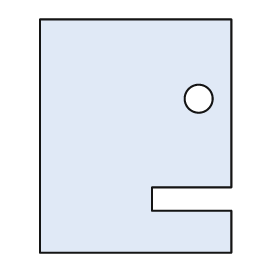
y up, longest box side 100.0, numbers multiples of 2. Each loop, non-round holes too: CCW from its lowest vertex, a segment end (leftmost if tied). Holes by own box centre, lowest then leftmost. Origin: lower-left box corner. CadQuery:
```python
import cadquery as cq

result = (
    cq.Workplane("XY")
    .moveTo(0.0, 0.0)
    .lineTo(82.0, 0.0)
    .lineTo(82.0, 18.0)
    .lineTo(48.0, 18.0)
    .lineTo(48.0, 28.0)
    .lineTo(82.0, 28.0)
    .lineTo(82.0, 100.0)
    .lineTo(0.0, 100.0)
    .close()
    .moveTo(68.0, 66.0)
    .circle(6.0)
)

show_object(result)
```